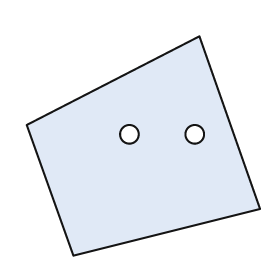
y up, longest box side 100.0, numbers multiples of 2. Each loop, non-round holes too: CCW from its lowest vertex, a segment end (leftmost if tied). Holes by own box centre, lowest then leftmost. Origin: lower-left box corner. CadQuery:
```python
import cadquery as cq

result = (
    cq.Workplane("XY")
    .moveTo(20.0, 0.0)
    .lineTo(100.0, 20.0)
    .lineTo(74.0, 94.0)
    .lineTo(0.0, 56.0)
    .close()
    .moveTo(44.0, 52.0)
    .circle(4.0)
    .moveTo(72.0, 52.0)
    .circle(4.0)
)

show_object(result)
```